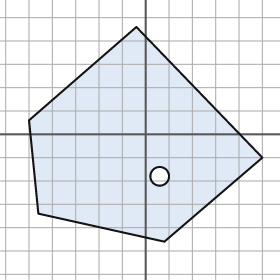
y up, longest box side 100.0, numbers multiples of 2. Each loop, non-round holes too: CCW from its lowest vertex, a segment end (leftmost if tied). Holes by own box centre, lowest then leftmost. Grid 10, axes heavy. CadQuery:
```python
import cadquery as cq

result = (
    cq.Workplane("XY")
    .moveTo(8.0, -46.0)
    .lineTo(50.0, -10.0)
    .lineTo(-4.0, 46.0)
    .lineTo(-50.0, 6.0)
    .lineTo(-46.0, -34.0)
    .close()
    .moveTo(6.0, -18.0)
    .circle(4.0)
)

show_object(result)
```